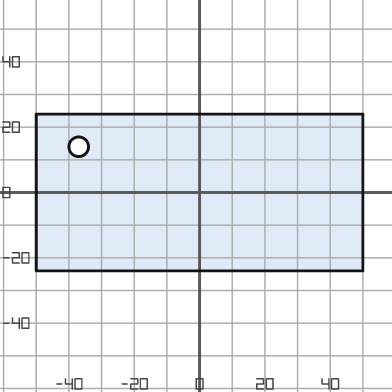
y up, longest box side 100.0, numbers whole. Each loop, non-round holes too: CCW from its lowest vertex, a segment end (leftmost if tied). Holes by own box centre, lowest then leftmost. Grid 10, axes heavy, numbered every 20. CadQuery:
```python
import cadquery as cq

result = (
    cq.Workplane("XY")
    .moveTo(-50.0, -24.0)
    .lineTo(50.0, -24.0)
    .lineTo(50.0, 24.0)
    .lineTo(-50.0, 24.0)
    .close()
    .moveTo(-37.0, 14.0)
    .circle(3.0)
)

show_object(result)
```